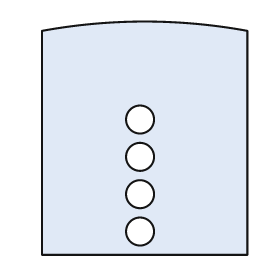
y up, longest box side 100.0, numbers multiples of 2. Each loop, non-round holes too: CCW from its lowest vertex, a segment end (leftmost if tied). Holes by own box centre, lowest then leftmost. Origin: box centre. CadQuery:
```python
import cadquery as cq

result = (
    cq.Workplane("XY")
    .moveTo(-44.0, -50.0)
    .lineTo(44.0, -50.0)
    .lineTo(44.0, 46.0)
    .threePointArc((0.0, 50.0), (-44.0, 46.0))
    .close()
    .moveTo(-2.0, -40.0)
    .circle(6.0)
    .moveTo(-2.0, -24.0)
    .circle(6.0)
    .moveTo(-2.0, -8.0)
    .circle(6.0)
    .moveTo(-2.0, 8.0)
    .circle(6.0)
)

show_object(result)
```